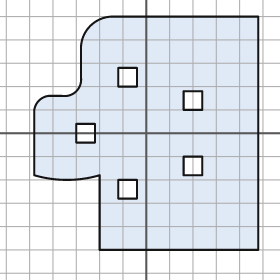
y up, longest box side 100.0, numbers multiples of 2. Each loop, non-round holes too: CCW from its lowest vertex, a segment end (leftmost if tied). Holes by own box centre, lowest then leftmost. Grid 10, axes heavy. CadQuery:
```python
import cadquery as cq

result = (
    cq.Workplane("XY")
    .moveTo(-20.0, -50.0)
    .lineTo(48.0, -50.0)
    .lineTo(48.0, 50.0)
    .lineTo(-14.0, 50.0)
    .threePointArc((-24.0, 46.0), (-28.0, 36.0))
    .lineTo(-28.0, 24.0)
    .threePointArc((-30.0, 18.0), (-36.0, 16.0))
    .lineTo(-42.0, 16.0)
    .threePointArc((-46.0, 14.0), (-48.0, 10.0))
    .lineTo(-48.0, -18.0)
    .threePointArc((-34.0, -20.0), (-20.0, -18.0))
    .close()
    .moveTo(-12.0, -28.0)
    .lineTo(-4.0, -28.0)
    .lineTo(-4.0, -20.0)
    .lineTo(-12.0, -20.0)
    .close()
    .moveTo(16.0, -18.0)
    .lineTo(24.0, -18.0)
    .lineTo(24.0, -10.0)
    .lineTo(16.0, -10.0)
    .close()
    .moveTo(-30.0, -4.0)
    .lineTo(-22.0, -4.0)
    .lineTo(-22.0, 4.0)
    .lineTo(-30.0, 4.0)
    .close()
    .moveTo(16.0, 10.0)
    .lineTo(24.0, 10.0)
    .lineTo(24.0, 18.0)
    .lineTo(16.0, 18.0)
    .close()
    .moveTo(-12.0, 20.0)
    .lineTo(-4.0, 20.0)
    .lineTo(-4.0, 28.0)
    .lineTo(-12.0, 28.0)
    .close()
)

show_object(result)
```